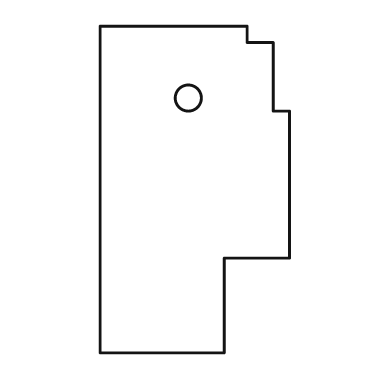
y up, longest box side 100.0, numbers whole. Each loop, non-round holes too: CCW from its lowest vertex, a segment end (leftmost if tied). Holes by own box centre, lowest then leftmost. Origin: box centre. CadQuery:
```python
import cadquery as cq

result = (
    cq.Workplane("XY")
    .moveTo(-29.0, -50.0)
    .lineTo(9.0, -50.0)
    .lineTo(9.0, -21.0)
    .lineTo(29.0, -21.0)
    .lineTo(29.0, 24.0)
    .lineTo(24.0, 24.0)
    .lineTo(24.0, 45.0)
    .lineTo(16.0, 45.0)
    .lineTo(16.0, 50.0)
    .lineTo(-29.0, 50.0)
    .close()
    .moveTo(-2.0, 28.0)
    .circle(4.0)
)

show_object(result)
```